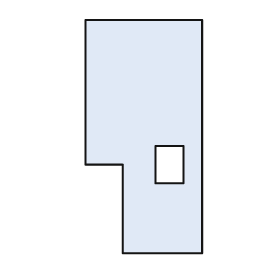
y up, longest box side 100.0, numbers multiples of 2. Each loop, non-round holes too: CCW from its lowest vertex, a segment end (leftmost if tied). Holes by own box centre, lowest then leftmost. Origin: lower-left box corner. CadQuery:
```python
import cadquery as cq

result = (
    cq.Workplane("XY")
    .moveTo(16.0, 0.0)
    .lineTo(50.0, 0.0)
    .lineTo(50.0, 100.0)
    .lineTo(0.0, 100.0)
    .lineTo(0.0, 38.0)
    .lineTo(16.0, 38.0)
    .close()
    .moveTo(30.0, 30.0)
    .lineTo(42.0, 30.0)
    .lineTo(42.0, 46.0)
    .lineTo(30.0, 46.0)
    .close()
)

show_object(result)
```